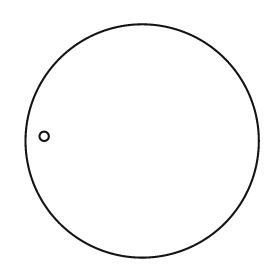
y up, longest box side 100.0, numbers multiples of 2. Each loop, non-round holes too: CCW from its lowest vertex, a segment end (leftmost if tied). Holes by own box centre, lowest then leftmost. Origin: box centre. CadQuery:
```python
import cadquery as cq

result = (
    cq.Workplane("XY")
    .moveTo(0.0, 0.0)
    .circle(50.0)
    .moveTo(-42.0, 2.0)
    .circle(2.0)
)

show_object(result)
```